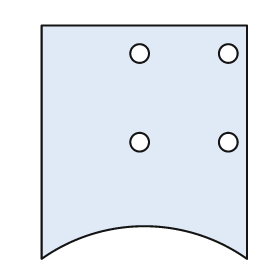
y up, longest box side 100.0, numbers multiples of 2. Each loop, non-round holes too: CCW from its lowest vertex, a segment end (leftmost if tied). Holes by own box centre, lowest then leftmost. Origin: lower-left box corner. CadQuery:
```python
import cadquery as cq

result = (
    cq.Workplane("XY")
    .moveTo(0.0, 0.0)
    .threePointArc((44.0, 14.0), (88.0, 0.0))
    .lineTo(88.0, 100.0)
    .lineTo(0.0, 100.0)
    .close()
    .moveTo(42.0, 50.0)
    .circle(4.0)
    .moveTo(80.0, 50.0)
    .circle(4.0)
    .moveTo(42.0, 88.0)
    .circle(4.0)
    .moveTo(80.0, 88.0)
    .circle(4.0)
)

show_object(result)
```